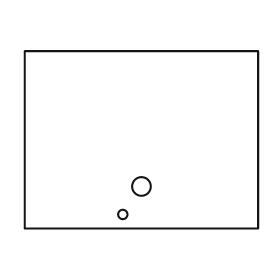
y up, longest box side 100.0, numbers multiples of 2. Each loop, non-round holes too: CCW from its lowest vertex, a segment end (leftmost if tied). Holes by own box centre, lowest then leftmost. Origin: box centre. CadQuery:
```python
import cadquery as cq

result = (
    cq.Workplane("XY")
    .moveTo(-50.0, -38.0)
    .lineTo(50.0, -38.0)
    .lineTo(50.0, 38.0)
    .lineTo(-50.0, 38.0)
    .close()
    .moveTo(-8.0, -32.0)
    .circle(2.0)
    .moveTo(0.0, -20.0)
    .circle(4.0)
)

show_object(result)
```